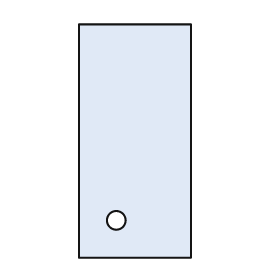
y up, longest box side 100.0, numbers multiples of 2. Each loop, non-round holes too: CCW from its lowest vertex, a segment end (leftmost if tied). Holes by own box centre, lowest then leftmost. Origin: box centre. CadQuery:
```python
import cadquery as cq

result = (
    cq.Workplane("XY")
    .moveTo(-24.0, -50.0)
    .lineTo(24.0, -50.0)
    .lineTo(24.0, 50.0)
    .lineTo(-24.0, 50.0)
    .close()
    .moveTo(-8.0, -34.0)
    .circle(4.0)
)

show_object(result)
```